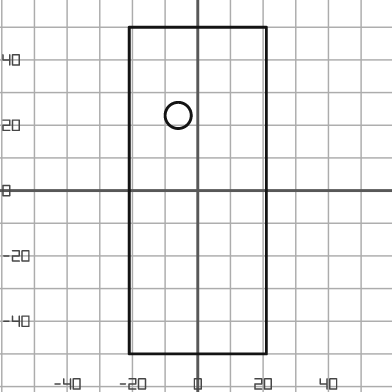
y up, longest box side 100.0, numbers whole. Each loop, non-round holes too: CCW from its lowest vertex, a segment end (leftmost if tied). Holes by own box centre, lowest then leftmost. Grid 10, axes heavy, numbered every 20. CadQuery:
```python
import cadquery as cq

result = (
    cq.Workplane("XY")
    .moveTo(-21.0, -50.0)
    .lineTo(21.0, -50.0)
    .lineTo(21.0, 50.0)
    .lineTo(-21.0, 50.0)
    .close()
    .moveTo(-6.0, 23.0)
    .circle(4.0)
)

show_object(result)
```